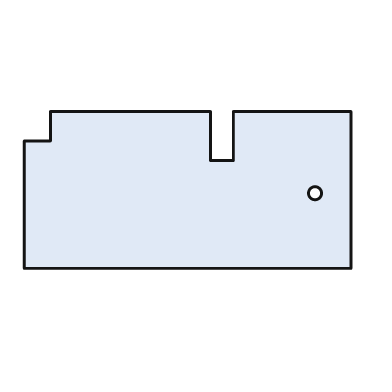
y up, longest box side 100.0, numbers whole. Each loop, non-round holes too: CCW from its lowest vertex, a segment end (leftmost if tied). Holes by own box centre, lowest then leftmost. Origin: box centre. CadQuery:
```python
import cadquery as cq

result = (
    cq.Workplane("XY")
    .moveTo(-50.0, -24.0)
    .lineTo(50.0, -24.0)
    .lineTo(50.0, 24.0)
    .lineTo(14.0, 24.0)
    .lineTo(14.0, 9.0)
    .lineTo(7.0, 9.0)
    .lineTo(7.0, 24.0)
    .lineTo(-42.0, 24.0)
    .lineTo(-42.0, 15.0)
    .lineTo(-50.0, 15.0)
    .close()
    .moveTo(39.0, -1.0)
    .circle(2.0)
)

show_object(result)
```